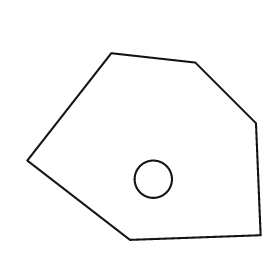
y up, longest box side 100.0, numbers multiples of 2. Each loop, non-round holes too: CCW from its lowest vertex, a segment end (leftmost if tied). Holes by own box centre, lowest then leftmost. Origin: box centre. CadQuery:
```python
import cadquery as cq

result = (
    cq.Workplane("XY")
    .moveTo(-6.0, -40.0)
    .lineTo(50.0, -38.0)
    .lineTo(48.0, 10.0)
    .lineTo(22.0, 36.0)
    .lineTo(-14.0, 40.0)
    .lineTo(-50.0, -6.0)
    .close()
    .moveTo(4.0, -14.0)
    .circle(8.0)
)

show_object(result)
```